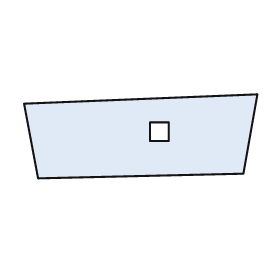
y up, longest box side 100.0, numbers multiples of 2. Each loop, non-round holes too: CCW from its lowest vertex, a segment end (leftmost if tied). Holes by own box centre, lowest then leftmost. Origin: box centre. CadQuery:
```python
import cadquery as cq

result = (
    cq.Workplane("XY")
    .moveTo(-44.0, -18.0)
    .lineTo(44.0, -16.0)
    .lineTo(50.0, 18.0)
    .lineTo(-50.0, 14.0)
    .close()
    .moveTo(4.0, -2.0)
    .lineTo(12.0, -2.0)
    .lineTo(12.0, 6.0)
    .lineTo(4.0, 6.0)
    .close()
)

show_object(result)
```